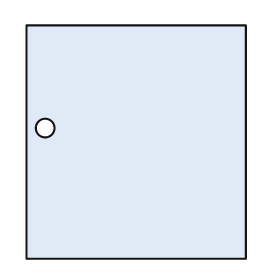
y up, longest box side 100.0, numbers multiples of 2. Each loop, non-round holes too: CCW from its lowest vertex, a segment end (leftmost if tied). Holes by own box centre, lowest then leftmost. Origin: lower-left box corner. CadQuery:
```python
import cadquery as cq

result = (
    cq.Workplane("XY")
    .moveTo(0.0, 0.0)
    .lineTo(94.0, 0.0)
    .lineTo(94.0, 100.0)
    .lineTo(0.0, 100.0)
    .close()
    .moveTo(8.0, 56.0)
    .circle(4.0)
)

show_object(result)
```